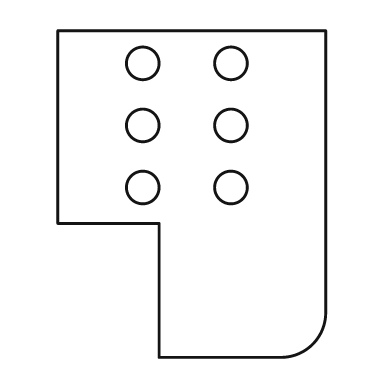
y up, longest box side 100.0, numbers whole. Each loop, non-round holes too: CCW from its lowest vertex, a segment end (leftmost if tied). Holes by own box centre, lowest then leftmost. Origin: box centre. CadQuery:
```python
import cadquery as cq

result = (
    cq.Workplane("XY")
    .moveTo(-10.0, -50.0)
    .lineTo(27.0, -50.0)
    .threePointArc((37.0, -46.0), (41.0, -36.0))
    .lineTo(41.0, 50.0)
    .lineTo(-41.0, 50.0)
    .lineTo(-41.0, -9.0)
    .lineTo(-10.0, -9.0)
    .close()
    .moveTo(-15.0, 2.0)
    .circle(5.0)
    .moveTo(12.0, 2.0)
    .circle(5.0)
    .moveTo(-15.0, 21.0)
    .circle(5.0)
    .moveTo(12.0, 21.0)
    .circle(5.0)
    .moveTo(-15.0, 40.0)
    .circle(5.0)
    .moveTo(12.0, 40.0)
    .circle(5.0)
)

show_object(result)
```